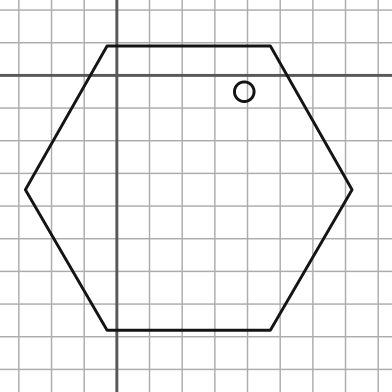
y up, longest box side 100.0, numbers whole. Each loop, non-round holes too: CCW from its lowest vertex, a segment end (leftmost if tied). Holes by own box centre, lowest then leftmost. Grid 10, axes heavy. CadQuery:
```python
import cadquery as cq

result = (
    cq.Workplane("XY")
    .moveTo(-3.0, -78.0)
    .lineTo(47.0, -78.0)
    .lineTo(72.0, -35.0)
    .lineTo(47.0, 9.0)
    .lineTo(-3.0, 9.0)
    .lineTo(-28.0, -35.0)
    .close()
    .moveTo(39.0, -5.0)
    .circle(3.0)
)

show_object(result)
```